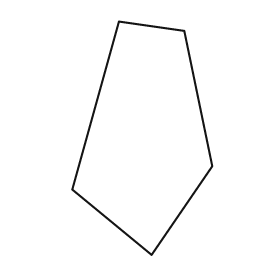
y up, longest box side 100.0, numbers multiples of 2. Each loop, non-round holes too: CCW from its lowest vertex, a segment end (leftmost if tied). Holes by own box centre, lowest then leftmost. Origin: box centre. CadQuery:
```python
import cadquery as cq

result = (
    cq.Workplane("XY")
    .moveTo(4.0, -50.0)
    .lineTo(30.0, -12.0)
    .lineTo(18.0, 46.0)
    .lineTo(-10.0, 50.0)
    .lineTo(-30.0, -22.0)
    .close()
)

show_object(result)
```